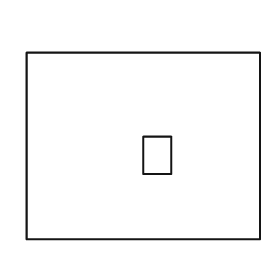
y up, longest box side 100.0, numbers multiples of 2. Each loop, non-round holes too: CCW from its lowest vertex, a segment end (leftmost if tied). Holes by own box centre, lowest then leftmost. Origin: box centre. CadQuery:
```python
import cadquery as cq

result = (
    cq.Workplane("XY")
    .moveTo(-50.0, -40.0)
    .lineTo(50.0, -40.0)
    .lineTo(50.0, 40.0)
    .lineTo(-50.0, 40.0)
    .close()
    .moveTo(0.0, -12.0)
    .lineTo(12.0, -12.0)
    .lineTo(12.0, 4.0)
    .lineTo(0.0, 4.0)
    .close()
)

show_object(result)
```